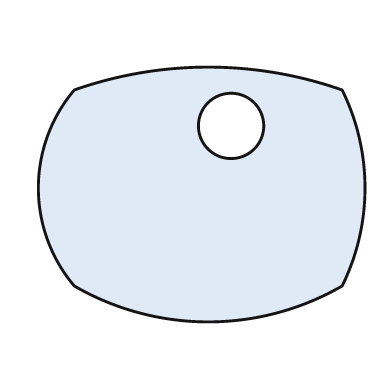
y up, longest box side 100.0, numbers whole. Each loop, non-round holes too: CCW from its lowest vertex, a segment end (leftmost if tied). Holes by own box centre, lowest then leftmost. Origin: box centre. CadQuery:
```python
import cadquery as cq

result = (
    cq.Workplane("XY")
    .moveTo(-39.0, -28.0)
    .threePointArc((2.0, -39.0), (43.0, -28.0))
    .threePointArc((50.0, 2.0), (43.0, 32.0))
    .threePointArc((2.0, 39.0), (-39.0, 32.0))
    .threePointArc((-50.0, 2.0), (-39.0, -28.0))
    .close()
    .moveTo(9.0, 21.0)
    .circle(10.0)
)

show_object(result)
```